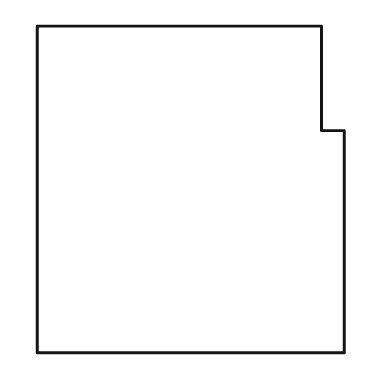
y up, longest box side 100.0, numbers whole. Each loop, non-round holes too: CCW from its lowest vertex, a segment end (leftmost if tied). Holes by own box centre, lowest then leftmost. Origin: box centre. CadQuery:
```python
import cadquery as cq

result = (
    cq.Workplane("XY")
    .moveTo(-47.0, -50.0)
    .lineTo(47.0, -50.0)
    .lineTo(47.0, 18.0)
    .lineTo(40.0, 18.0)
    .lineTo(40.0, 50.0)
    .lineTo(-47.0, 50.0)
    .close()
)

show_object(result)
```